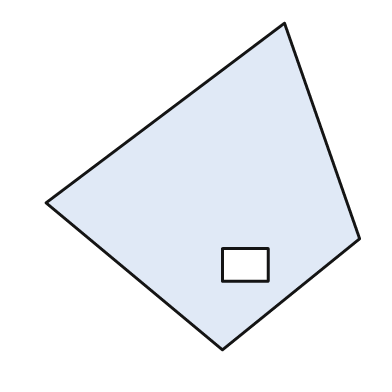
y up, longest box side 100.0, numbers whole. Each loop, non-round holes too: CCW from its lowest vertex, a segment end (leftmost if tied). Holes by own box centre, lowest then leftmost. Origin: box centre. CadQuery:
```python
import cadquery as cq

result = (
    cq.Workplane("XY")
    .moveTo(6.0, -50.0)
    .lineTo(48.0, -16.0)
    .lineTo(25.0, 50.0)
    .lineTo(-48.0, -5.0)
    .close()
    .moveTo(6.0, -29.0)
    .lineTo(20.0, -29.0)
    .lineTo(20.0, -19.0)
    .lineTo(6.0, -19.0)
    .close()
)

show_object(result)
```